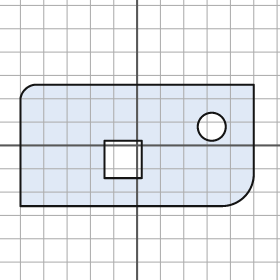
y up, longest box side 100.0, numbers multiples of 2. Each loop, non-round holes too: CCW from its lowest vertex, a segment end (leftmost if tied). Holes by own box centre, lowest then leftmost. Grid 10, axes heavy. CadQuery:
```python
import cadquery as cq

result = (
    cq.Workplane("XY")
    .moveTo(-50.0, -26.0)
    .lineTo(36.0, -26.0)
    .threePointArc((46.0, -22.0), (50.0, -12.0))
    .lineTo(50.0, 26.0)
    .lineTo(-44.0, 26.0)
    .threePointArc((-48.0, 24.0), (-50.0, 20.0))
    .close()
    .moveTo(-14.0, -14.0)
    .lineTo(2.0, -14.0)
    .lineTo(2.0, 2.0)
    .lineTo(-14.0, 2.0)
    .close()
    .moveTo(32.0, 8.0)
    .circle(6.0)
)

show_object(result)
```